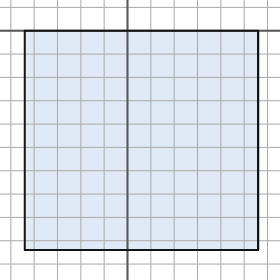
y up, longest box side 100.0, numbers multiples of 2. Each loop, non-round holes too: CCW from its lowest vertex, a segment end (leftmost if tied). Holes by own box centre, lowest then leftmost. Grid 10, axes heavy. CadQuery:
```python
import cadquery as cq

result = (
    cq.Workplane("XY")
    .moveTo(-44.0, -94.0)
    .lineTo(56.0, -94.0)
    .lineTo(56.0, 0.0)
    .lineTo(-44.0, 0.0)
    .close()
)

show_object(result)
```